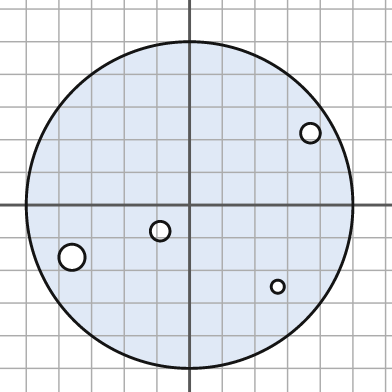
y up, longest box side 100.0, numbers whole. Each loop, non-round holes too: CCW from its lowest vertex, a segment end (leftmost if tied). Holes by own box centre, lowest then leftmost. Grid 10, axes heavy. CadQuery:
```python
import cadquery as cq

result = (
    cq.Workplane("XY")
    .moveTo(0.0, 0.0)
    .circle(50.0)
    .moveTo(27.0, -25.0)
    .circle(2.0)
    .moveTo(-36.0, -16.0)
    .circle(4.0)
    .moveTo(-9.0, -8.0)
    .circle(3.0)
    .moveTo(37.0, 22.0)
    .circle(3.0)
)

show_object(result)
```